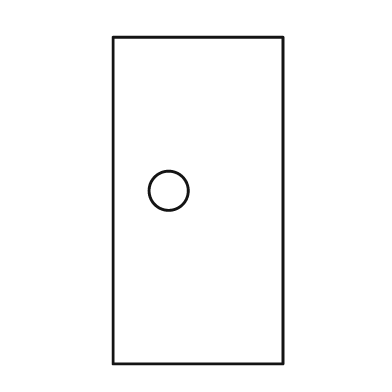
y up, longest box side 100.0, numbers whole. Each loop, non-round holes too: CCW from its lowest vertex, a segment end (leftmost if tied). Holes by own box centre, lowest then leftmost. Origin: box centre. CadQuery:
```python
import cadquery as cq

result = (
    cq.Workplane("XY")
    .moveTo(-26.0, -50.0)
    .lineTo(26.0, -50.0)
    .lineTo(26.0, 50.0)
    .lineTo(-26.0, 50.0)
    .close()
    .moveTo(-9.0, 3.0)
    .circle(6.0)
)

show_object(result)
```